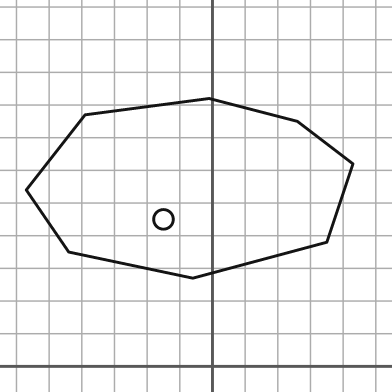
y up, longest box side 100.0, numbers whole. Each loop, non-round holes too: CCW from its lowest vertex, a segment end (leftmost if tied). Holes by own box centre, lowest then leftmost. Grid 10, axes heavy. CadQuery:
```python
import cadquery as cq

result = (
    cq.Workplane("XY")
    .moveTo(-6.0, 27.0)
    .lineTo(35.0, 38.0)
    .lineTo(43.0, 62.0)
    .lineTo(26.0, 75.0)
    .lineTo(-1.0, 82.0)
    .lineTo(-39.0, 77.0)
    .lineTo(-57.0, 54.0)
    .lineTo(-44.0, 35.0)
    .close()
    .moveTo(-15.0, 45.0)
    .circle(3.0)
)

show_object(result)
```